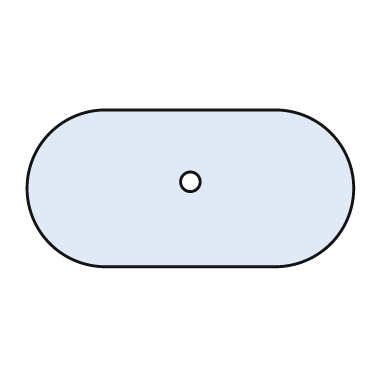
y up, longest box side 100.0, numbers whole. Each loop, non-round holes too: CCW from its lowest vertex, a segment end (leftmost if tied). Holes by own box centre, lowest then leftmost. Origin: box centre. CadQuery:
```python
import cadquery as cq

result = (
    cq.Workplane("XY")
    .moveTo(-26.0, -24.0)
    .lineTo(26.0, -24.0)
    .threePointArc((50.0, 0.0), (26.0, 24.0))
    .lineTo(-26.0, 24.0)
    .threePointArc((-50.0, 0.0), (-26.0, -24.0))
    .close()
    .moveTo(0.0, 2.0)
    .circle(3.0)
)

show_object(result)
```